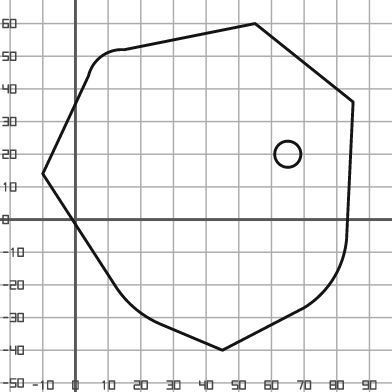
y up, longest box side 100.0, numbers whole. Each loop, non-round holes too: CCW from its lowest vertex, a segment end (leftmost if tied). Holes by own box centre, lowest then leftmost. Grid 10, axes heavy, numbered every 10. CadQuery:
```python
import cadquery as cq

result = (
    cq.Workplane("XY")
    .moveTo(45.0, -40.0)
    .lineTo(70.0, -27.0)
    .threePointArc((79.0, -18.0), (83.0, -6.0))
    .lineTo(85.0, 36.0)
    .lineTo(55.0, 60.0)
    .lineTo(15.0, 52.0)
    .threePointArc((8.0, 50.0), (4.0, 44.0))
    .lineTo(-10.0, 14.0)
    .lineTo(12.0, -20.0)
    .threePointArc((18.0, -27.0), (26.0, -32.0))
    .close()
    .moveTo(65.0, 20.0)
    .circle(4.0)
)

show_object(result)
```